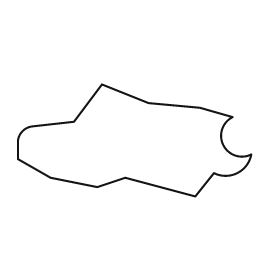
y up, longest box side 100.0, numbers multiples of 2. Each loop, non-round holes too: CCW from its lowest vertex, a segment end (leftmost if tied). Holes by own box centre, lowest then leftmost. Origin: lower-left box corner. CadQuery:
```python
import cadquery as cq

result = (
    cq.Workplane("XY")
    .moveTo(76.0, 0.0)
    .lineTo(84.0, 10.0)
    .threePointArc((94.0, 10.0), (100.0, 18.0))
    .threePointArc((88.0, 22.0), (92.0, 34.0))
    .lineTo(78.0, 38.0)
    .lineTo(56.0, 40.0)
    .lineTo(36.0, 48.0)
    .lineTo(24.0, 32.0)
    .lineTo(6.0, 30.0)
    .threePointArc((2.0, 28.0), (0.0, 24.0))
    .lineTo(0.0, 16.0)
    .lineTo(14.0, 8.0)
    .lineTo(34.0, 4.0)
    .lineTo(46.0, 8.0)
    .close()
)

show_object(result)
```